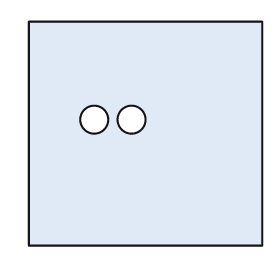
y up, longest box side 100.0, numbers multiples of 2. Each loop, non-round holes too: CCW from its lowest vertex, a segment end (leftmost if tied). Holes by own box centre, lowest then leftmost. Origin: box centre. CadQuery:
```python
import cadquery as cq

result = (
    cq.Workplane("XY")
    .moveTo(-50.0, -48.0)
    .lineTo(50.0, -48.0)
    .lineTo(50.0, 48.0)
    .lineTo(-50.0, 48.0)
    .close()
    .moveTo(-22.0, 6.0)
    .circle(6.0)
    .moveTo(-6.0, 6.0)
    .circle(6.0)
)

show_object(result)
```